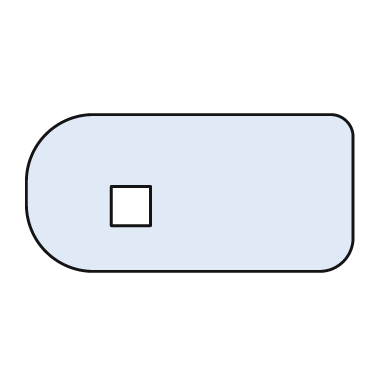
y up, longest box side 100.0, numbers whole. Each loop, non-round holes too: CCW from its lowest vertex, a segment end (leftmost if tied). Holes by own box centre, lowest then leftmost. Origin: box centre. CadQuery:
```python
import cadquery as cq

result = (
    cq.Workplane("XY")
    .moveTo(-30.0, -24.0)
    .lineTo(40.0, -24.0)
    .threePointArc((47.0, -21.0), (50.0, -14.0))
    .lineTo(50.0, 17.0)
    .threePointArc((48.0, 22.0), (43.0, 24.0))
    .lineTo(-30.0, 24.0)
    .threePointArc((-44.0, 18.0), (-50.0, 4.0))
    .lineTo(-50.0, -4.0)
    .threePointArc((-44.0, -18.0), (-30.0, -24.0))
    .close()
    .moveTo(-24.0, -10.0)
    .lineTo(-12.0, -10.0)
    .lineTo(-12.0, 2.0)
    .lineTo(-24.0, 2.0)
    .close()
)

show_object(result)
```